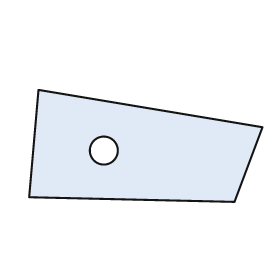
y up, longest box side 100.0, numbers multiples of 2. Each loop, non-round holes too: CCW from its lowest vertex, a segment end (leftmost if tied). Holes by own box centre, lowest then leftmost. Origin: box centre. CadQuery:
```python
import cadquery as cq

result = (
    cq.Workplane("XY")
    .moveTo(38.0, -24.0)
    .lineTo(50.0, 8.0)
    .lineTo(-46.0, 24.0)
    .lineTo(-50.0, -22.0)
    .close()
    .moveTo(-18.0, -2.0)
    .circle(6.0)
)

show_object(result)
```